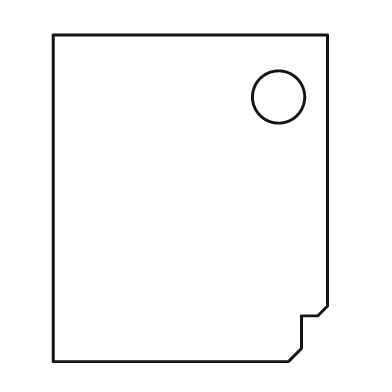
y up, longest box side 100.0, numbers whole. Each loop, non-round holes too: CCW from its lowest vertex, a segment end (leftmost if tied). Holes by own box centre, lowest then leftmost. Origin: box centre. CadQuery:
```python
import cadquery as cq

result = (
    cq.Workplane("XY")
    .moveTo(-42.0, -50.0)
    .lineTo(30.0, -50.0)
    .lineTo(34.0, -46.0)
    .lineTo(34.0, -36.0)
    .lineTo(39.0, -36.0)
    .lineTo(42.0, -33.0)
    .lineTo(42.0, 50.0)
    .lineTo(-42.0, 50.0)
    .close()
    .moveTo(27.0, 31.0)
    .circle(8.0)
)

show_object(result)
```